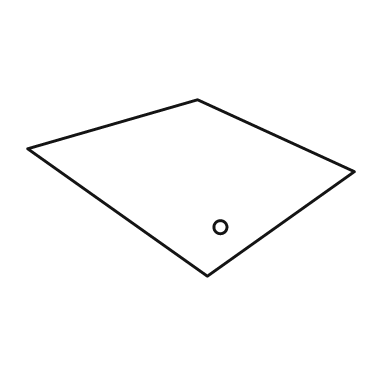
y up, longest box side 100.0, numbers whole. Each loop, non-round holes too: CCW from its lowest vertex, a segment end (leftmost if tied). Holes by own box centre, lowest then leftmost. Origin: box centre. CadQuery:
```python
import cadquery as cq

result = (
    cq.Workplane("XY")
    .moveTo(5.0, -27.0)
    .lineTo(50.0, 5.0)
    .lineTo(2.0, 27.0)
    .lineTo(-50.0, 12.0)
    .close()
    .moveTo(9.0, -12.0)
    .circle(2.0)
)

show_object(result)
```